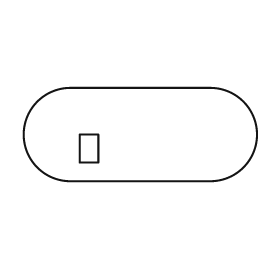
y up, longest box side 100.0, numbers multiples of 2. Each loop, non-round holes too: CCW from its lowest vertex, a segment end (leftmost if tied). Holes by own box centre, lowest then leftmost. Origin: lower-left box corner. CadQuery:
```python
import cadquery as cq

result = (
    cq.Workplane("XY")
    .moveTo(20.0, 0.0)
    .lineTo(80.0, 0.0)
    .threePointArc((100.0, 20.0), (80.0, 40.0))
    .lineTo(20.0, 40.0)
    .threePointArc((0.0, 20.0), (20.0, 0.0))
    .close()
    .moveTo(24.0, 8.0)
    .lineTo(32.0, 8.0)
    .lineTo(32.0, 20.0)
    .lineTo(24.0, 20.0)
    .close()
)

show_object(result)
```